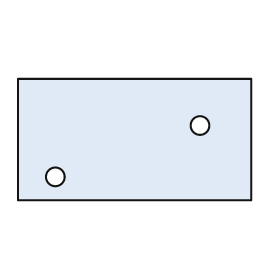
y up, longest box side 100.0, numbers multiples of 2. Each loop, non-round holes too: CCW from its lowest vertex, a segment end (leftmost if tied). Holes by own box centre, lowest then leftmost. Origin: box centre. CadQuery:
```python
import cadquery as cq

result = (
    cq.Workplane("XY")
    .moveTo(-50.0, -26.0)
    .lineTo(50.0, -26.0)
    .lineTo(50.0, 26.0)
    .lineTo(-50.0, 26.0)
    .close()
    .moveTo(-34.0, -16.0)
    .circle(4.0)
    .moveTo(28.0, 6.0)
    .circle(4.0)
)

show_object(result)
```